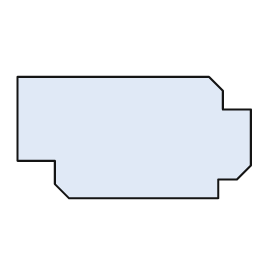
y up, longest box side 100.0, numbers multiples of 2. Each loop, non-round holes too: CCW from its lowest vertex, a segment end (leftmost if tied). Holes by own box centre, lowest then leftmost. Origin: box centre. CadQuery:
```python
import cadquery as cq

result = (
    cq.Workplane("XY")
    .moveTo(-28.0, -26.0)
    .lineTo(36.0, -26.0)
    .lineTo(36.0, -18.0)
    .lineTo(44.0, -18.0)
    .lineTo(50.0, -12.0)
    .lineTo(50.0, 12.0)
    .lineTo(38.0, 12.0)
    .lineTo(38.0, 20.0)
    .lineTo(32.0, 26.0)
    .lineTo(-50.0, 26.0)
    .lineTo(-50.0, -10.0)
    .lineTo(-34.0, -10.0)
    .lineTo(-34.0, -20.0)
    .close()
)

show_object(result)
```